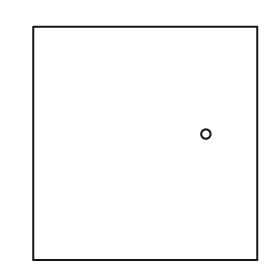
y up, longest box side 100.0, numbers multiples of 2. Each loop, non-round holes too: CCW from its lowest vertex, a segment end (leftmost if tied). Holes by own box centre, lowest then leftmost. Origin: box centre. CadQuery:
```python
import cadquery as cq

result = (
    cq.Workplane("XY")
    .moveTo(-48.0, -50.0)
    .lineTo(48.0, -50.0)
    .lineTo(48.0, 50.0)
    .lineTo(-48.0, 50.0)
    .close()
    .moveTo(26.0, 4.0)
    .circle(2.0)
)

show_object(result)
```